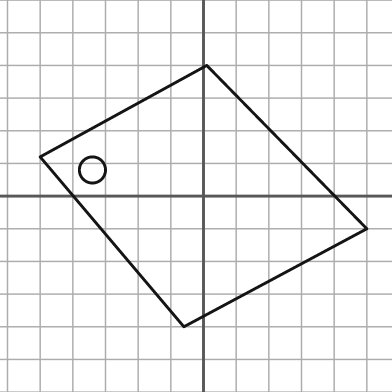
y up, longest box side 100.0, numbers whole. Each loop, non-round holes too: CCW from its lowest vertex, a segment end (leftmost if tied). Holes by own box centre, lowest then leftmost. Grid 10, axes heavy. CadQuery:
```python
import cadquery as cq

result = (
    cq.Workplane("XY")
    .moveTo(-6.0, -40.0)
    .lineTo(50.0, -10.0)
    .lineTo(1.0, 40.0)
    .lineTo(-50.0, 12.0)
    .close()
    .moveTo(-34.0, 8.0)
    .circle(4.0)
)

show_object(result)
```